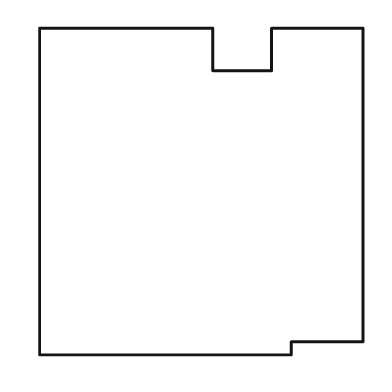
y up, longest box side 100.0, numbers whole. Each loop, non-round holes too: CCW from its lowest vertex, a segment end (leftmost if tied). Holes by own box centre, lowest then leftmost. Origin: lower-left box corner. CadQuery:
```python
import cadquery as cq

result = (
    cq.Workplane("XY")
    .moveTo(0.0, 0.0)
    .lineTo(77.0, 0.0)
    .lineTo(77.0, 4.0)
    .lineTo(99.0, 4.0)
    .lineTo(99.0, 100.0)
    .lineTo(71.0, 100.0)
    .lineTo(71.0, 87.0)
    .lineTo(53.0, 87.0)
    .lineTo(53.0, 100.0)
    .lineTo(0.0, 100.0)
    .close()
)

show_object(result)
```